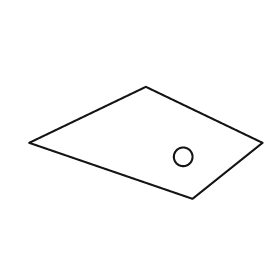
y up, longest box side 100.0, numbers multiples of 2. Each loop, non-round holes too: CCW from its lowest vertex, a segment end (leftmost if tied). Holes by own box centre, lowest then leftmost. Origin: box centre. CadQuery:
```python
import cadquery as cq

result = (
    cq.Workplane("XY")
    .moveTo(20.0, -24.0)
    .lineTo(50.0, 0.0)
    .lineTo(0.0, 24.0)
    .lineTo(-50.0, 0.0)
    .close()
    .moveTo(16.0, -6.0)
    .circle(4.0)
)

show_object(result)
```